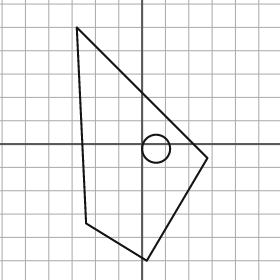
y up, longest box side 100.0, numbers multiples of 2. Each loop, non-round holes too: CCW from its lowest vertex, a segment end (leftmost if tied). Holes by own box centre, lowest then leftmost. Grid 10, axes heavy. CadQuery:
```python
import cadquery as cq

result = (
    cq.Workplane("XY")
    .moveTo(2.0, -50.0)
    .lineTo(28.0, -6.0)
    .lineTo(-28.0, 50.0)
    .lineTo(-24.0, -34.0)
    .close()
    .moveTo(6.0, -2.0)
    .circle(6.0)
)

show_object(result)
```